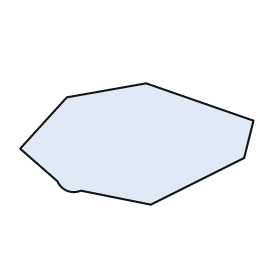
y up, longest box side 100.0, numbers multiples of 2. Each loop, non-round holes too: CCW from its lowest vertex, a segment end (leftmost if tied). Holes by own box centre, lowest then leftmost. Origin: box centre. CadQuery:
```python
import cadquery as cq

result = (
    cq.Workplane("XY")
    .moveTo(6.0, -26.0)
    .lineTo(46.0, -6.0)
    .lineTo(50.0, 10.0)
    .lineTo(4.0, 26.0)
    .lineTo(-30.0, 20.0)
    .lineTo(-50.0, -2.0)
    .lineTo(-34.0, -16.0)
    .threePointArc((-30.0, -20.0), (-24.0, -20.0))
    .close()
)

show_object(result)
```